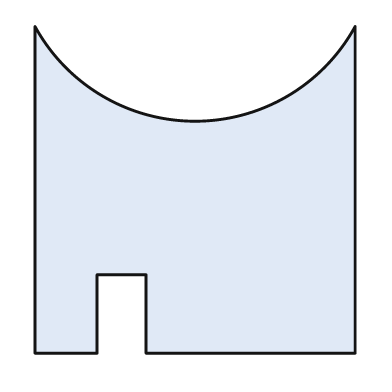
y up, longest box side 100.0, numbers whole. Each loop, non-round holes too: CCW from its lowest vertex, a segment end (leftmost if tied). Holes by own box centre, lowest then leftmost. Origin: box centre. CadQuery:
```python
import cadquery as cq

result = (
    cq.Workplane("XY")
    .moveTo(-49.0, -50.0)
    .lineTo(-30.0, -50.0)
    .lineTo(-30.0, -26.0)
    .lineTo(-15.0, -26.0)
    .lineTo(-15.0, -50.0)
    .lineTo(49.0, -50.0)
    .lineTo(49.0, 50.0)
    .threePointArc((0.0, 21.0), (-49.0, 50.0))
    .close()
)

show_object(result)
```